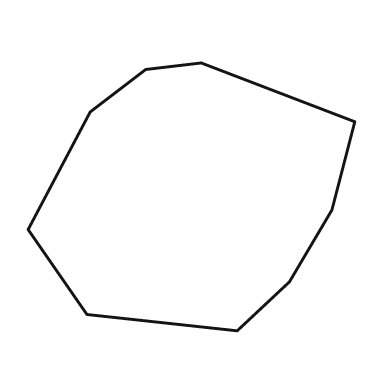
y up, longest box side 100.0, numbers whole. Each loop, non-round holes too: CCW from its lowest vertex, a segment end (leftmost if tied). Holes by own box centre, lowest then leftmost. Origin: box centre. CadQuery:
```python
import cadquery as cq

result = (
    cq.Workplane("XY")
    .moveTo(14.0, -41.0)
    .lineTo(30.0, -26.0)
    .lineTo(43.0, -4.0)
    .lineTo(50.0, 23.0)
    .lineTo(3.0, 41.0)
    .lineTo(-14.0, 39.0)
    .lineTo(-31.0, 26.0)
    .lineTo(-50.0, -10.0)
    .lineTo(-32.0, -36.0)
    .close()
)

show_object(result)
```